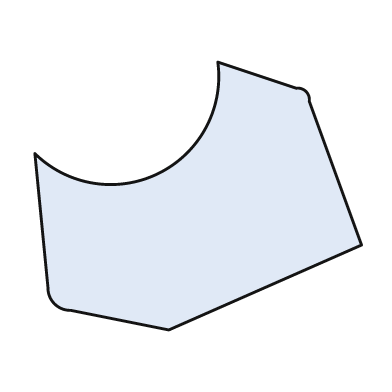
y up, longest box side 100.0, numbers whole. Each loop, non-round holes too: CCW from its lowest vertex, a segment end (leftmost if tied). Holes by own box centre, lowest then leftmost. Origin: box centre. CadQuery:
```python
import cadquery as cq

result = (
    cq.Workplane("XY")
    .moveTo(-9.0, -41.0)
    .lineTo(50.0, -15.0)
    .lineTo(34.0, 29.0)
    .threePointArc((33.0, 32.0), (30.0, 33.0))
    .lineTo(6.0, 41.0)
    .threePointArc((-12.0, 7.0), (-50.0, 13.0))
    .lineTo(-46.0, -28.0)
    .threePointArc((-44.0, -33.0), (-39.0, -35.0))
    .close()
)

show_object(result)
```